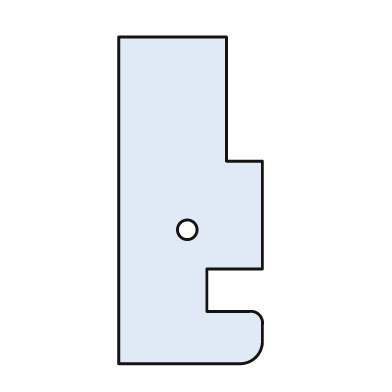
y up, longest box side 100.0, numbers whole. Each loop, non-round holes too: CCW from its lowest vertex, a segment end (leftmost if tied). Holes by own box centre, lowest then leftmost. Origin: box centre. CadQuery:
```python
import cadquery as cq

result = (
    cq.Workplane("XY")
    .moveTo(-22.0, -50.0)
    .lineTo(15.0, -50.0)
    .threePointArc((20.0, -48.0), (22.0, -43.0))
    .lineTo(22.0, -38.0)
    .threePointArc((21.0, -35.0), (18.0, -34.0))
    .lineTo(5.0, -34.0)
    .lineTo(5.0, -21.0)
    .lineTo(22.0, -21.0)
    .lineTo(22.0, 12.0)
    .lineTo(11.0, 12.0)
    .lineTo(11.0, 50.0)
    .lineTo(-22.0, 50.0)
    .close()
    .moveTo(-1.0, -9.0)
    .circle(3.0)
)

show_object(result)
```